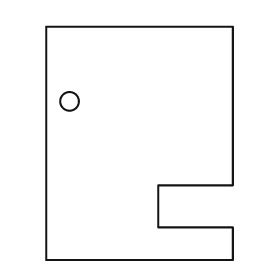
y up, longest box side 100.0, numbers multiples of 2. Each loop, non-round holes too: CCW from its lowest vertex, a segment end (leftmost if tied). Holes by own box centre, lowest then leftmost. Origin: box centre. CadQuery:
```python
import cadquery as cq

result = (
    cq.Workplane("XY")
    .moveTo(-40.0, -50.0)
    .lineTo(40.0, -50.0)
    .lineTo(40.0, -36.0)
    .lineTo(8.0, -36.0)
    .lineTo(8.0, -18.0)
    .lineTo(40.0, -18.0)
    .lineTo(40.0, 50.0)
    .lineTo(-40.0, 50.0)
    .close()
    .moveTo(-30.0, 18.0)
    .circle(4.0)
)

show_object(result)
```